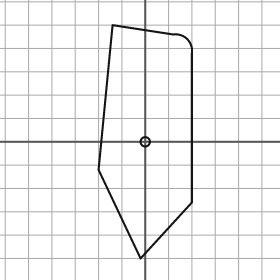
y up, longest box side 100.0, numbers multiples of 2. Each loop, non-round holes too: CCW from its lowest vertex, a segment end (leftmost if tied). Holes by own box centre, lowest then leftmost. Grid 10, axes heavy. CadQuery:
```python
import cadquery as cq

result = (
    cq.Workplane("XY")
    .moveTo(-2.0, -50.0)
    .lineTo(20.0, -26.0)
    .lineTo(20.0, 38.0)
    .threePointArc((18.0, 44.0), (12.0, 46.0))
    .lineTo(-14.0, 50.0)
    .lineTo(-20.0, -12.0)
    .close()
    .moveTo(0.0, 0.0)
    .circle(2.0)
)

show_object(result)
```